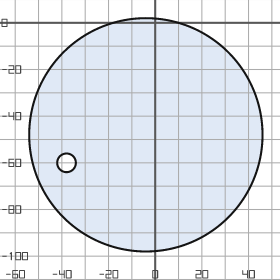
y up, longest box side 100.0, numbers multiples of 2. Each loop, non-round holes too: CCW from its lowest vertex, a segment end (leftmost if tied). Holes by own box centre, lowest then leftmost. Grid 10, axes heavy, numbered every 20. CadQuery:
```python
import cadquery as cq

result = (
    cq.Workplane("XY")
    .moveTo(-4.0, -48.0)
    .circle(50.0)
    .moveTo(-38.0, -60.0)
    .circle(4.0)
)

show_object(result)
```